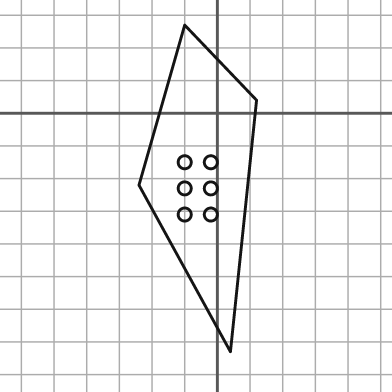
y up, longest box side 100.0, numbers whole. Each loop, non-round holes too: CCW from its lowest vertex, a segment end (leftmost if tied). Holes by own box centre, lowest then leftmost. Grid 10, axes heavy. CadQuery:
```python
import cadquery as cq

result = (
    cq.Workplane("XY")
    .moveTo(4.0, -73.0)
    .lineTo(12.0, 4.0)
    .lineTo(-10.0, 27.0)
    .lineTo(-24.0, -22.0)
    .close()
    .moveTo(-10.0, -31.0)
    .circle(2.0)
    .moveTo(-2.0, -31.0)
    .circle(2.0)
    .moveTo(-10.0, -23.0)
    .circle(2.0)
    .moveTo(-2.0, -23.0)
    .circle(2.0)
    .moveTo(-10.0, -15.0)
    .circle(2.0)
    .moveTo(-2.0, -15.0)
    .circle(2.0)
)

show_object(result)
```